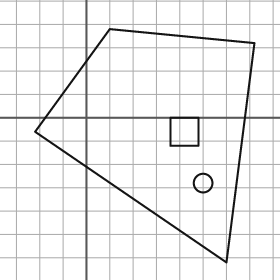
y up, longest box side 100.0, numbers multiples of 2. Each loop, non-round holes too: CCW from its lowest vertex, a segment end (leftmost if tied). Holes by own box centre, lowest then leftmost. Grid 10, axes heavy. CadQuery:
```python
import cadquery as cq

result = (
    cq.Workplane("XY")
    .moveTo(60.0, -62.0)
    .lineTo(72.0, 32.0)
    .lineTo(10.0, 38.0)
    .lineTo(-22.0, -6.0)
    .close()
    .moveTo(50.0, -28.0)
    .circle(4.0)
    .moveTo(36.0, -12.0)
    .lineTo(48.0, -12.0)
    .lineTo(48.0, 0.0)
    .lineTo(36.0, 0.0)
    .close()
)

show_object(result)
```